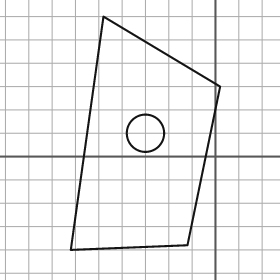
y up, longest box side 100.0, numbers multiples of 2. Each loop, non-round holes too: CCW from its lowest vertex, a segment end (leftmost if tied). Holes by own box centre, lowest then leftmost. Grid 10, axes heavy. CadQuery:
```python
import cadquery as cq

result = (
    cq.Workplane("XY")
    .moveTo(-62.0, -40.0)
    .lineTo(-12.0, -38.0)
    .lineTo(2.0, 30.0)
    .lineTo(-48.0, 60.0)
    .close()
    .moveTo(-30.0, 10.0)
    .circle(8.0)
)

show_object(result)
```